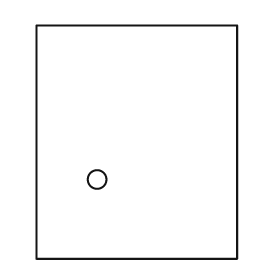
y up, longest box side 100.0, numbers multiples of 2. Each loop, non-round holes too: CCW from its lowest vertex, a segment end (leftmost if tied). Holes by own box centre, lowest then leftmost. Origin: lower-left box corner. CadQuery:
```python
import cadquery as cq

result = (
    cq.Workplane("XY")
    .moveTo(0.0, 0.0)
    .lineTo(86.0, 0.0)
    .lineTo(86.0, 100.0)
    .lineTo(0.0, 100.0)
    .close()
    .moveTo(26.0, 34.0)
    .circle(4.0)
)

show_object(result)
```